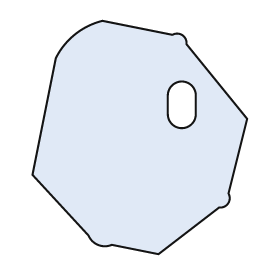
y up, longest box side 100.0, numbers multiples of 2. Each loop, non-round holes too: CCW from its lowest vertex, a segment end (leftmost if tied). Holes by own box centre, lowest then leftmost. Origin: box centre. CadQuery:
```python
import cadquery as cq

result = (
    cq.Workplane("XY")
    .moveTo(8.0, -50.0)
    .lineTo(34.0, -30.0)
    .threePointArc((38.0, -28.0), (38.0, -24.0))
    .lineTo(46.0, 8.0)
    .lineTo(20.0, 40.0)
    .threePointArc((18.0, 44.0), (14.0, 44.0))
    .lineTo(-16.0, 50.0)
    .threePointArc((-28.0, 44.0), (-36.0, 34.0))
    .lineTo(-46.0, -16.0)
    .lineTo(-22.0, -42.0)
    .threePointArc((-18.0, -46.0), (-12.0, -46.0))
    .close()
    .moveTo(12.0, 10.0)
    .threePointArc((18.0, 4.0), (24.0, 10.0))
    .lineTo(24.0, 18.0)
    .threePointArc((18.0, 24.0), (12.0, 18.0))
    .close()
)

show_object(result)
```